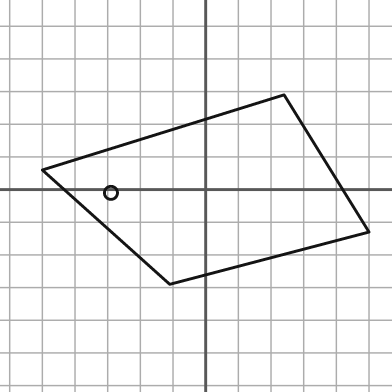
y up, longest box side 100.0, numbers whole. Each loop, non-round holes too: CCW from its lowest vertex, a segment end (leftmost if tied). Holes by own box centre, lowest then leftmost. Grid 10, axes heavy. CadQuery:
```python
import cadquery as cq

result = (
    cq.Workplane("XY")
    .moveTo(-11.0, -29.0)
    .lineTo(50.0, -13.0)
    .lineTo(24.0, 29.0)
    .lineTo(-50.0, 6.0)
    .close()
    .moveTo(-29.0, -1.0)
    .circle(2.0)
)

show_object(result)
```